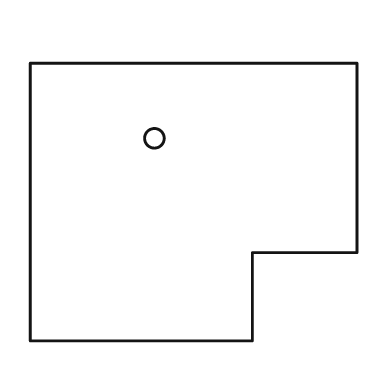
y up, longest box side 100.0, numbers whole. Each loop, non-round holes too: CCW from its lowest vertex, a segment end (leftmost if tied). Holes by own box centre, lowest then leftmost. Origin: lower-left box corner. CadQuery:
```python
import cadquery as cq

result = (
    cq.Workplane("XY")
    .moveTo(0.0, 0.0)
    .lineTo(68.0, 0.0)
    .lineTo(68.0, 27.0)
    .lineTo(100.0, 27.0)
    .lineTo(100.0, 85.0)
    .lineTo(0.0, 85.0)
    .close()
    .moveTo(38.0, 62.0)
    .circle(3.0)
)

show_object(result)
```